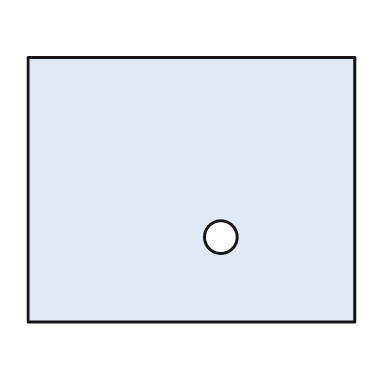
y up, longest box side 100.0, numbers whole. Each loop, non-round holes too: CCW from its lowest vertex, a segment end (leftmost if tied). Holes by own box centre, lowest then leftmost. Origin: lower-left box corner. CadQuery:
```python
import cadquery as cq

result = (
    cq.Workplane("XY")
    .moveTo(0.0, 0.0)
    .lineTo(100.0, 0.0)
    .lineTo(100.0, 81.0)
    .lineTo(0.0, 81.0)
    .close()
    .moveTo(59.0, 26.0)
    .circle(5.0)
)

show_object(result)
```